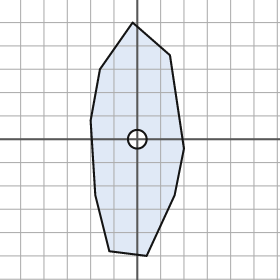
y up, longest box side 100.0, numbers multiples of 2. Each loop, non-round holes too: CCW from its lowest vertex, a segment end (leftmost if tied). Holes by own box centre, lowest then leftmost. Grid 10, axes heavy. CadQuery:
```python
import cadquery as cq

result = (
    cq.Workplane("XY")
    .moveTo(4.0, -50.0)
    .lineTo(16.0, -24.0)
    .lineTo(20.0, -4.0)
    .lineTo(14.0, 36.0)
    .lineTo(-2.0, 50.0)
    .lineTo(-16.0, 30.0)
    .lineTo(-20.0, 8.0)
    .lineTo(-18.0, -24.0)
    .lineTo(-12.0, -48.0)
    .close()
    .moveTo(0.0, 0.0)
    .circle(4.0)
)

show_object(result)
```